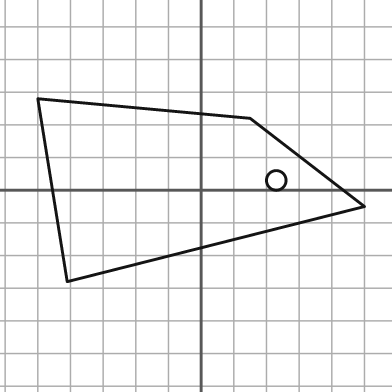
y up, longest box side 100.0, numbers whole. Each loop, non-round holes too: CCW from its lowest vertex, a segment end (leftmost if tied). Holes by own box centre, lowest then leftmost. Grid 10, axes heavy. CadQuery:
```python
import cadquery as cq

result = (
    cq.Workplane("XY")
    .moveTo(-41.0, -28.0)
    .lineTo(50.0, -5.0)
    .lineTo(15.0, 22.0)
    .lineTo(-50.0, 28.0)
    .close()
    .moveTo(23.0, 3.0)
    .circle(3.0)
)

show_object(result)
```